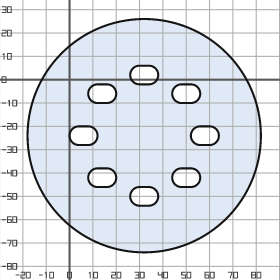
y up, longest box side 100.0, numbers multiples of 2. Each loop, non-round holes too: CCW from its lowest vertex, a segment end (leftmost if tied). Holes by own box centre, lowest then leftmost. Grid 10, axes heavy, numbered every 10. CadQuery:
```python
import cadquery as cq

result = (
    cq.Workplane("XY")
    .moveTo(32.0, -24.0)
    .circle(50.0)
    .moveTo(30.0, -54.0)
    .lineTo(34.0, -54.0)
    .threePointArc((38.0, -50.0), (34.0, -46.0))
    .lineTo(30.0, -46.0)
    .threePointArc((26.0, -50.0), (30.0, -54.0))
    .close()
    .moveTo(12.0, -46.0)
    .lineTo(16.0, -46.0)
    .threePointArc((20.0, -42.0), (16.0, -38.0))
    .lineTo(12.0, -38.0)
    .threePointArc((8.0, -42.0), (12.0, -46.0))
    .close()
    .moveTo(48.0, -46.0)
    .lineTo(52.0, -46.0)
    .threePointArc((56.0, -42.0), (52.0, -38.0))
    .lineTo(48.0, -38.0)
    .threePointArc((44.0, -42.0), (48.0, -46.0))
    .close()
    .moveTo(4.0, -28.0)
    .lineTo(8.0, -28.0)
    .threePointArc((12.0, -24.0), (8.0, -20.0))
    .lineTo(4.0, -20.0)
    .threePointArc((0.0, -24.0), (4.0, -28.0))
    .close()
    .moveTo(56.0, -28.0)
    .lineTo(60.0, -28.0)
    .threePointArc((64.0, -24.0), (60.0, -20.0))
    .lineTo(56.0, -20.0)
    .threePointArc((52.0, -24.0), (56.0, -28.0))
    .close()
    .moveTo(12.0, -10.0)
    .lineTo(16.0, -10.0)
    .threePointArc((20.0, -6.0), (16.0, -2.0))
    .lineTo(12.0, -2.0)
    .threePointArc((8.0, -6.0), (12.0, -10.0))
    .close()
    .moveTo(48.0, -10.0)
    .lineTo(52.0, -10.0)
    .threePointArc((56.0, -6.0), (52.0, -2.0))
    .lineTo(48.0, -2.0)
    .threePointArc((44.0, -6.0), (48.0, -10.0))
    .close()
    .moveTo(30.0, -2.0)
    .lineTo(34.0, -2.0)
    .threePointArc((38.0, 2.0), (34.0, 6.0))
    .lineTo(30.0, 6.0)
    .threePointArc((26.0, 2.0), (30.0, -2.0))
    .close()
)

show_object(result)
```